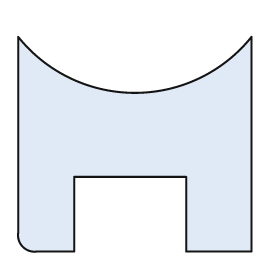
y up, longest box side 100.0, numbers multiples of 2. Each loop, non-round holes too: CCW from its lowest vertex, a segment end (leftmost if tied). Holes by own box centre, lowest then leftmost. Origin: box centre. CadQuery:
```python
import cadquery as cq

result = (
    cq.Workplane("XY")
    .moveTo(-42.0, -46.0)
    .lineTo(-26.0, -46.0)
    .lineTo(-26.0, -14.0)
    .lineTo(22.0, -14.0)
    .lineTo(22.0, -46.0)
    .lineTo(50.0, -46.0)
    .lineTo(50.0, 46.0)
    .threePointArc((0.0, 22.0), (-50.0, 46.0))
    .lineTo(-50.0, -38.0)
    .threePointArc((-48.0, -44.0), (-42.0, -46.0))
    .close()
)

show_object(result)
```